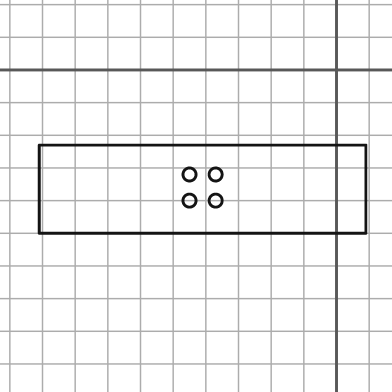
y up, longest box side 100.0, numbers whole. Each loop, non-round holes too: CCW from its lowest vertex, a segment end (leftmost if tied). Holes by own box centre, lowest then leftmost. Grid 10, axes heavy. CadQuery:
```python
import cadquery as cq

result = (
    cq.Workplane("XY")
    .moveTo(-91.0, -50.0)
    .lineTo(9.0, -50.0)
    .lineTo(9.0, -23.0)
    .lineTo(-91.0, -23.0)
    .close()
    .moveTo(-45.0, -40.0)
    .circle(2.0)
    .moveTo(-37.0, -40.0)
    .circle(2.0)
    .moveTo(-45.0, -32.0)
    .circle(2.0)
    .moveTo(-37.0, -32.0)
    .circle(2.0)
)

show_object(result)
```